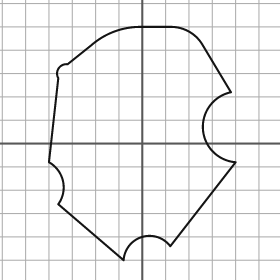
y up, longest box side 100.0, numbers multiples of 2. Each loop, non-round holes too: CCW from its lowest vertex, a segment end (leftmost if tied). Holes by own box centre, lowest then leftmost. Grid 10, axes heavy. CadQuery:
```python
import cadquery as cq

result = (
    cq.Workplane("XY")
    .moveTo(-8.0, -50.0)
    .threePointArc((0.0, -40.0), (12.0, -44.0))
    .lineTo(40.0, -8.0)
    .threePointArc((26.0, 6.0), (38.0, 22.0))
    .lineTo(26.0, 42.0)
    .threePointArc((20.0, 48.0), (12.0, 50.0))
    .lineTo(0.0, 50.0)
    .threePointArc((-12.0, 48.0), (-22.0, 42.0))
    .lineTo(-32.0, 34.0)
    .threePointArc((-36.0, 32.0), (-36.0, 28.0))
    .lineTo(-40.0, -8.0)
    .threePointArc((-34.0, -16.0), (-36.0, -26.0))
    .close()
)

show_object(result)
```